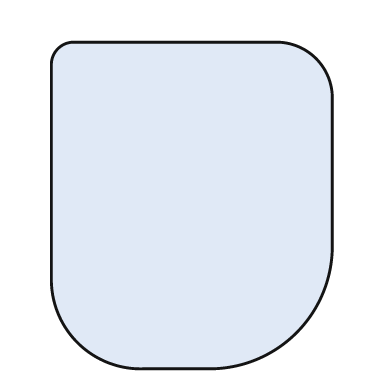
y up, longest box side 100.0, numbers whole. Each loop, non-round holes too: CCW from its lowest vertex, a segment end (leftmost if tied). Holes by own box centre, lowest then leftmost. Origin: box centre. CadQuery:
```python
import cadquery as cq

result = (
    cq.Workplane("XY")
    .moveTo(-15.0, -50.0)
    .lineTo(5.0, -50.0)
    .threePointArc((32.0, -39.0), (43.0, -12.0))
    .lineTo(43.0, 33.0)
    .threePointArc((38.0, 45.0), (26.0, 50.0))
    .lineTo(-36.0, 50.0)
    .threePointArc((-41.0, 48.0), (-43.0, 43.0))
    .lineTo(-43.0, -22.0)
    .threePointArc((-35.0, -42.0), (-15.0, -50.0))
    .close()
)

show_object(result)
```